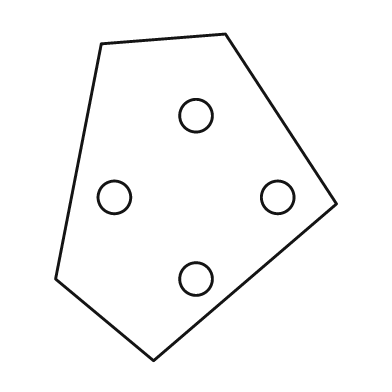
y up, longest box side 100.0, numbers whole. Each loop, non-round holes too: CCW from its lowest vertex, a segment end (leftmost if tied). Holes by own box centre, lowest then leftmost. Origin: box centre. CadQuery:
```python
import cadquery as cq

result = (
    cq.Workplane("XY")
    .moveTo(-13.0, -50.0)
    .lineTo(43.0, -2.0)
    .lineTo(9.0, 50.0)
    .lineTo(-29.0, 47.0)
    .lineTo(-43.0, -25.0)
    .close()
    .moveTo(0.0, -25.0)
    .circle(5.0)
    .moveTo(-25.0, 0.0)
    .circle(5.0)
    .moveTo(25.0, 0.0)
    .circle(5.0)
    .moveTo(0.0, 25.0)
    .circle(5.0)
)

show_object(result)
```